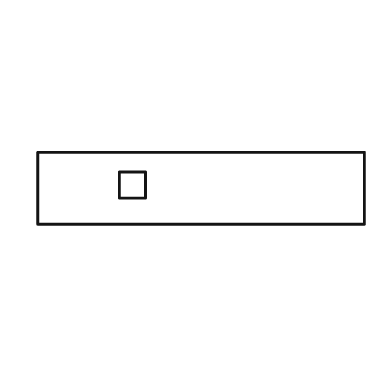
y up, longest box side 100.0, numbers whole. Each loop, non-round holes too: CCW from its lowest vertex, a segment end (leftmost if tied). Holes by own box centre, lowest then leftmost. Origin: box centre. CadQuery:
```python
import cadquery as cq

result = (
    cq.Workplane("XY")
    .moveTo(-50.0, -11.0)
    .lineTo(50.0, -11.0)
    .lineTo(50.0, 11.0)
    .lineTo(-50.0, 11.0)
    .close()
    .moveTo(-25.0, -3.0)
    .lineTo(-17.0, -3.0)
    .lineTo(-17.0, 5.0)
    .lineTo(-25.0, 5.0)
    .close()
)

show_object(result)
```